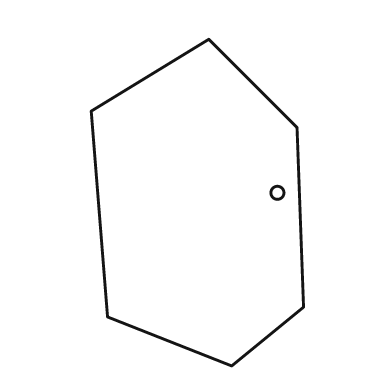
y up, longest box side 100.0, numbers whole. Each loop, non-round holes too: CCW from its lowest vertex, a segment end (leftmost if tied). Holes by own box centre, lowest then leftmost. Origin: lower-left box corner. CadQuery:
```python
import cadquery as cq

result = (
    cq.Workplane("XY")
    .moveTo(43.0, 0.0)
    .lineTo(65.0, 18.0)
    .lineTo(63.0, 73.0)
    .lineTo(36.0, 100.0)
    .lineTo(0.0, 78.0)
    .lineTo(5.0, 15.0)
    .close()
    .moveTo(57.0, 53.0)
    .circle(2.0)
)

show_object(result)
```